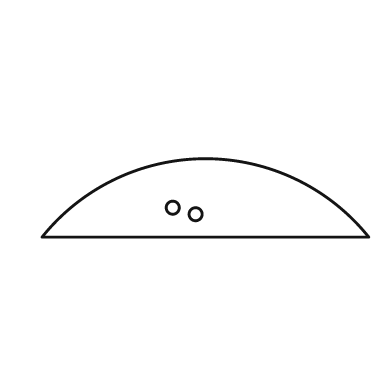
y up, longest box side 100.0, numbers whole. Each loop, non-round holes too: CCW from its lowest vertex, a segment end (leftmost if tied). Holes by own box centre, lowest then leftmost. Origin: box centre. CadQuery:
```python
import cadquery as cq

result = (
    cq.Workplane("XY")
    .moveTo(-50.0, -12.0)
    .lineTo(50.0, -12.0)
    .threePointArc((0.0, 12.0), (-50.0, -12.0))
    .close()
    .moveTo(-3.0, -5.0)
    .circle(2.0)
    .moveTo(-10.0, -3.0)
    .circle(2.0)
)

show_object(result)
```